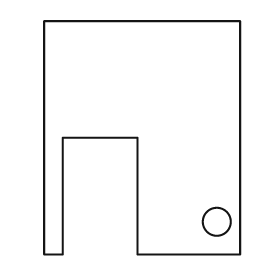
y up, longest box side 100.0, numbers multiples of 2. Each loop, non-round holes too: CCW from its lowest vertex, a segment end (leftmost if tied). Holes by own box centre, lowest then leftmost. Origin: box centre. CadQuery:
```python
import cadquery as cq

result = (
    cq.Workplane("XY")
    .moveTo(-42.0, -50.0)
    .lineTo(-34.0, -50.0)
    .lineTo(-34.0, 0.0)
    .lineTo(-2.0, 0.0)
    .lineTo(-2.0, -50.0)
    .lineTo(42.0, -50.0)
    .lineTo(42.0, 50.0)
    .lineTo(-42.0, 50.0)
    .close()
    .moveTo(32.0, -36.0)
    .circle(6.0)
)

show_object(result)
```